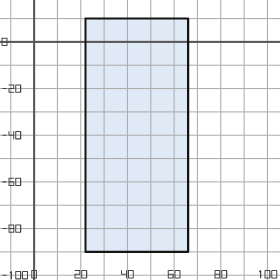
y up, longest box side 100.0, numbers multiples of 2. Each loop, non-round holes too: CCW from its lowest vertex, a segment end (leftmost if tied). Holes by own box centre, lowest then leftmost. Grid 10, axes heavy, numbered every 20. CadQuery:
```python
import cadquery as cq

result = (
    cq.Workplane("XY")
    .moveTo(22.0, -90.0)
    .lineTo(66.0, -90.0)
    .lineTo(66.0, 10.0)
    .lineTo(22.0, 10.0)
    .close()
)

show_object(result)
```